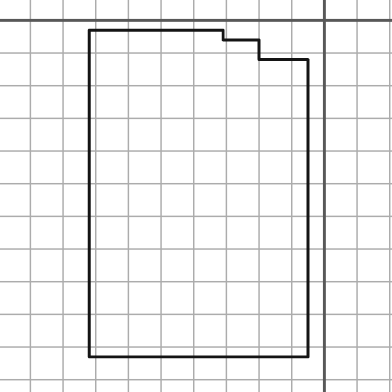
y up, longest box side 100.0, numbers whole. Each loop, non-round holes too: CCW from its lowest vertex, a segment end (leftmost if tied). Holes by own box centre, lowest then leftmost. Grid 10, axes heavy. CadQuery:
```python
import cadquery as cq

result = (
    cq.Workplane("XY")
    .moveTo(-72.0, -103.0)
    .lineTo(-5.0, -103.0)
    .lineTo(-5.0, -12.0)
    .lineTo(-20.0, -12.0)
    .lineTo(-20.0, -6.0)
    .lineTo(-31.0, -6.0)
    .lineTo(-31.0, -3.0)
    .lineTo(-72.0, -3.0)
    .close()
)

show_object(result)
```